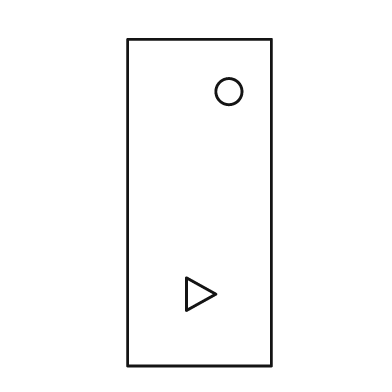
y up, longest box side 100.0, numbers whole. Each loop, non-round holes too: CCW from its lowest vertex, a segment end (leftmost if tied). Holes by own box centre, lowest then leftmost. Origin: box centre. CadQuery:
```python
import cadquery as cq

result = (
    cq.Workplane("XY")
    .moveTo(-22.0, -50.0)
    .lineTo(22.0, -50.0)
    .lineTo(22.0, 50.0)
    .lineTo(-22.0, 50.0)
    .close()
    .moveTo(-4.0, -33.0)
    .lineTo(5.0, -28.0)
    .lineTo(-4.0, -23.0)
    .close()
    .moveTo(9.0, 34.0)
    .circle(4.0)
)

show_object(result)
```